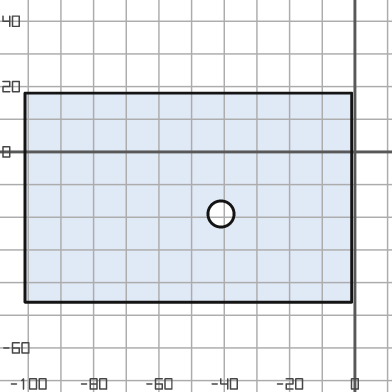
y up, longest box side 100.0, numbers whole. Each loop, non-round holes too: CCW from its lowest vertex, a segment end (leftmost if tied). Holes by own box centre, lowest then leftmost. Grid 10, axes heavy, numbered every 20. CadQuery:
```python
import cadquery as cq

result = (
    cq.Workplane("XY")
    .moveTo(-101.0, -46.0)
    .lineTo(-1.0, -46.0)
    .lineTo(-1.0, 18.0)
    .lineTo(-101.0, 18.0)
    .close()
    .moveTo(-41.0, -19.0)
    .circle(4.0)
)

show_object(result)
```